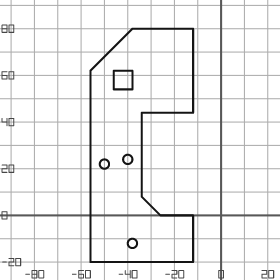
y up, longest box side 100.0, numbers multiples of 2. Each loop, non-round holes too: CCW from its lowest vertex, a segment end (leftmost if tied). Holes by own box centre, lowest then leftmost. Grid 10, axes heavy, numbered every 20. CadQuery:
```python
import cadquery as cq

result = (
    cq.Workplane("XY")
    .moveTo(-56.0, -20.0)
    .lineTo(-12.0, -20.0)
    .lineTo(-12.0, 0.0)
    .lineTo(-26.0, 0.0)
    .lineTo(-34.0, 8.0)
    .lineTo(-34.0, 44.0)
    .lineTo(-12.0, 44.0)
    .lineTo(-12.0, 80.0)
    .lineTo(-38.0, 80.0)
    .lineTo(-56.0, 62.0)
    .close()
    .moveTo(-38.0, -12.0)
    .circle(2.0)
    .moveTo(-50.0, 22.0)
    .circle(2.0)
    .moveTo(-40.0, 24.0)
    .circle(2.0)
    .moveTo(-46.0, 54.0)
    .lineTo(-38.0, 54.0)
    .lineTo(-38.0, 62.0)
    .lineTo(-46.0, 62.0)
    .close()
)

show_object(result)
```